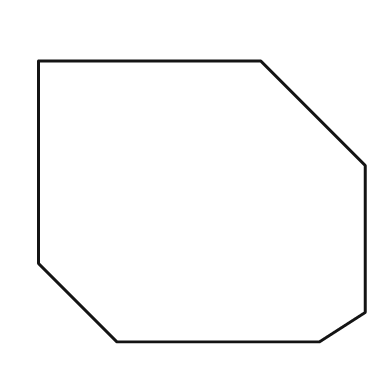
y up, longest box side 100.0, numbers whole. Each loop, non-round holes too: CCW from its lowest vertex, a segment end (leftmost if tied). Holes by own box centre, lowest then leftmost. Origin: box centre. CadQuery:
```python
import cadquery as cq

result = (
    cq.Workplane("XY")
    .moveTo(-26.0, -43.0)
    .lineTo(36.0, -43.0)
    .lineTo(50.0, -34.0)
    .lineTo(50.0, 11.0)
    .lineTo(18.0, 43.0)
    .lineTo(-50.0, 43.0)
    .lineTo(-50.0, -19.0)
    .close()
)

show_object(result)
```